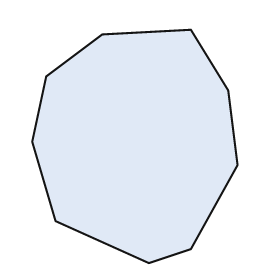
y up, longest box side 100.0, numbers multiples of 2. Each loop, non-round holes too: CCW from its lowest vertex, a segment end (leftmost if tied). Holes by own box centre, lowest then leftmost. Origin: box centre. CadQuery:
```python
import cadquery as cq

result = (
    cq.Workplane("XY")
    .moveTo(6.0, -50.0)
    .lineTo(24.0, -44.0)
    .lineTo(44.0, -8.0)
    .lineTo(40.0, 24.0)
    .lineTo(24.0, 50.0)
    .lineTo(-14.0, 48.0)
    .lineTo(-38.0, 30.0)
    .lineTo(-44.0, 2.0)
    .lineTo(-34.0, -32.0)
    .close()
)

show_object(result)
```